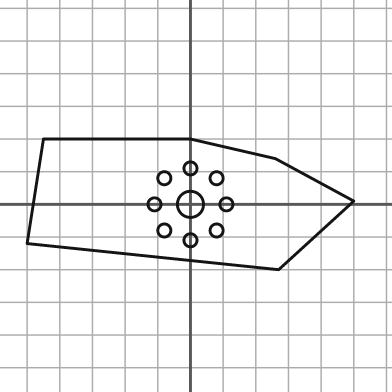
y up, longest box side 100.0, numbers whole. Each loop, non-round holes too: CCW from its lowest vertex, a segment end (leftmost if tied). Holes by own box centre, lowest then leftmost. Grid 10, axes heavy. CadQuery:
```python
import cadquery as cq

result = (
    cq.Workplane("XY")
    .moveTo(27.0, -20.0)
    .lineTo(50.0, 1.0)
    .lineTo(26.0, 14.0)
    .lineTo(0.0, 20.0)
    .lineTo(-45.0, 20.0)
    .lineTo(-50.0, -12.0)
    .close()
    .moveTo(0.0, -11.0)
    .circle(2.0)
    .moveTo(-8.0, -8.0)
    .circle(2.0)
    .moveTo(8.0, -8.0)
    .circle(2.0)
    .moveTo(-11.0, 0.0)
    .circle(2.0)
    .moveTo(0.0, 0.0)
    .circle(4.0)
    .moveTo(11.0, 0.0)
    .circle(2.0)
    .moveTo(-8.0, 8.0)
    .circle(2.0)
    .moveTo(8.0, 8.0)
    .circle(2.0)
    .moveTo(0.0, 11.0)
    .circle(2.0)
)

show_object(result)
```